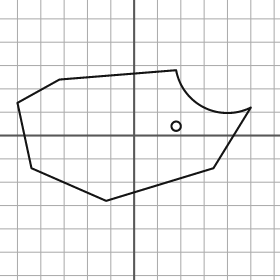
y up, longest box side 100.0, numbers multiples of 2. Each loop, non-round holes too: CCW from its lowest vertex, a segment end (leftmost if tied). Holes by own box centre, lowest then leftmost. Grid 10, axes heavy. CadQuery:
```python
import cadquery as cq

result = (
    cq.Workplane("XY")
    .moveTo(-12.0, -28.0)
    .lineTo(34.0, -14.0)
    .lineTo(50.0, 12.0)
    .threePointArc((30.0, 12.0), (18.0, 28.0))
    .lineTo(-32.0, 24.0)
    .lineTo(-50.0, 14.0)
    .lineTo(-44.0, -14.0)
    .close()
    .moveTo(18.0, 4.0)
    .circle(2.0)
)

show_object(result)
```